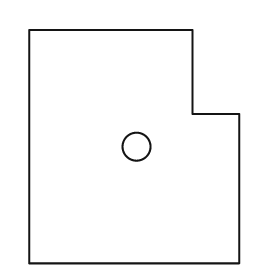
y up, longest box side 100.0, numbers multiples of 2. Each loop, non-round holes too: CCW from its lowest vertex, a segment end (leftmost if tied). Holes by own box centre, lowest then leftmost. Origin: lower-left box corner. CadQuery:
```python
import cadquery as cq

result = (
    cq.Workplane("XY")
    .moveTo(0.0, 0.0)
    .lineTo(90.0, 0.0)
    .lineTo(90.0, 64.0)
    .lineTo(70.0, 64.0)
    .lineTo(70.0, 100.0)
    .lineTo(0.0, 100.0)
    .close()
    .moveTo(46.0, 50.0)
    .circle(6.0)
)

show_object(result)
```